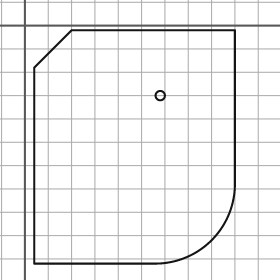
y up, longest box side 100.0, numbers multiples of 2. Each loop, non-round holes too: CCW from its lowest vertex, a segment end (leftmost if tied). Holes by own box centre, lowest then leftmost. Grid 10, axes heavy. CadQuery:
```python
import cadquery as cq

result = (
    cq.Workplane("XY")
    .moveTo(4.0, -102.0)
    .lineTo(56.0, -102.0)
    .threePointArc((80.0, -92.0), (90.0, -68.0))
    .lineTo(90.0, -2.0)
    .lineTo(20.0, -2.0)
    .lineTo(4.0, -18.0)
    .close()
    .moveTo(58.0, -30.0)
    .circle(2.0)
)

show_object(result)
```